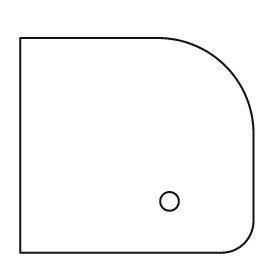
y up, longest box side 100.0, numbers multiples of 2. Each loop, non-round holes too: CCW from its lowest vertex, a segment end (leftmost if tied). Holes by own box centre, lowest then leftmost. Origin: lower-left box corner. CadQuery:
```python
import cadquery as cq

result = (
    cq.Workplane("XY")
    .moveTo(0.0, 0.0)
    .lineTo(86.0, 0.0)
    .threePointArc((96.0, 4.0), (100.0, 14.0))
    .lineTo(100.0, 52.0)
    .threePointArc((88.0, 80.0), (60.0, 92.0))
    .lineTo(0.0, 92.0)
    .close()
    .moveTo(64.0, 22.0)
    .circle(4.0)
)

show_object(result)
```